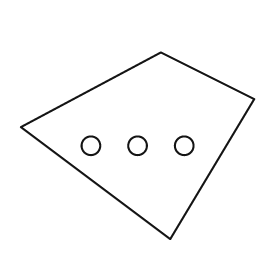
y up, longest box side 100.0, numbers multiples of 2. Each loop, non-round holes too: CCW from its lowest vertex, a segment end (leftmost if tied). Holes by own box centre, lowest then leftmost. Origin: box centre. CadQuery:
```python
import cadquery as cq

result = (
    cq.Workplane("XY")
    .moveTo(14.0, -40.0)
    .lineTo(50.0, 20.0)
    .lineTo(10.0, 40.0)
    .lineTo(-50.0, 8.0)
    .close()
    .moveTo(-20.0, 0.0)
    .circle(4.0)
    .moveTo(0.0, 0.0)
    .circle(4.0)
    .moveTo(20.0, 0.0)
    .circle(4.0)
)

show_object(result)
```